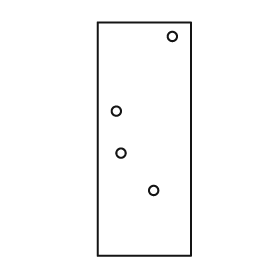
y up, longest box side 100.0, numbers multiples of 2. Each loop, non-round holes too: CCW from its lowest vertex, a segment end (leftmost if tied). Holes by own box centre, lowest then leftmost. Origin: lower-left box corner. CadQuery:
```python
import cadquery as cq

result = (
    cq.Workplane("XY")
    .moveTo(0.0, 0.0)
    .lineTo(40.0, 0.0)
    .lineTo(40.0, 100.0)
    .lineTo(0.0, 100.0)
    .close()
    .moveTo(24.0, 28.0)
    .circle(2.0)
    .moveTo(10.0, 44.0)
    .circle(2.0)
    .moveTo(8.0, 62.0)
    .circle(2.0)
    .moveTo(32.0, 94.0)
    .circle(2.0)
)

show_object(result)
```